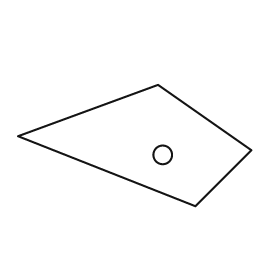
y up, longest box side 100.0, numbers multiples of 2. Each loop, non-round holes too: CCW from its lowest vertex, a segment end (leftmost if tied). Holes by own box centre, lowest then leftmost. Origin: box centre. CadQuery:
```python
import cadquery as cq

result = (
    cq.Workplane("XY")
    .moveTo(26.0, -26.0)
    .lineTo(50.0, -2.0)
    .lineTo(10.0, 26.0)
    .lineTo(-50.0, 4.0)
    .close()
    .moveTo(12.0, -4.0)
    .circle(4.0)
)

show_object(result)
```